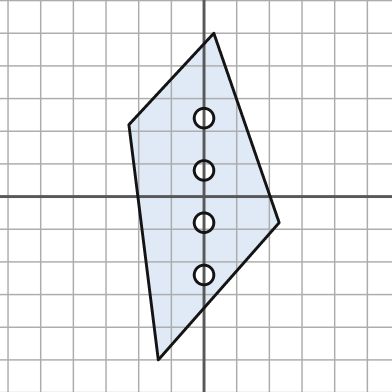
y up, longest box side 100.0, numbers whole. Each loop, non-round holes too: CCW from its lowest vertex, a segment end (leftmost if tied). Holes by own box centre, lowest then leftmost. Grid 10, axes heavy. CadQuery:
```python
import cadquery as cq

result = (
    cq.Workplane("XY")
    .moveTo(-14.0, -50.0)
    .lineTo(23.0, -8.0)
    .lineTo(3.0, 50.0)
    .lineTo(-23.0, 22.0)
    .close()
    .moveTo(0.0, -24.0)
    .circle(3.0)
    .moveTo(0.0, -8.0)
    .circle(3.0)
    .moveTo(0.0, 8.0)
    .circle(3.0)
    .moveTo(0.0, 24.0)
    .circle(3.0)
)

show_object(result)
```